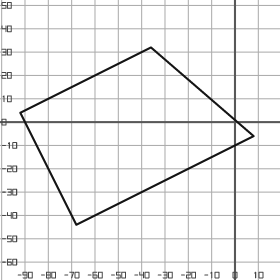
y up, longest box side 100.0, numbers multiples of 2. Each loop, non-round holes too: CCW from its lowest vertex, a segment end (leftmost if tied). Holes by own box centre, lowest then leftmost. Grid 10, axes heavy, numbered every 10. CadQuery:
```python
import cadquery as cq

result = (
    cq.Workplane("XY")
    .moveTo(-68.0, -44.0)
    .lineTo(8.0, -6.0)
    .lineTo(-36.0, 32.0)
    .lineTo(-92.0, 4.0)
    .close()
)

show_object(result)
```